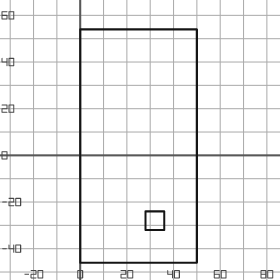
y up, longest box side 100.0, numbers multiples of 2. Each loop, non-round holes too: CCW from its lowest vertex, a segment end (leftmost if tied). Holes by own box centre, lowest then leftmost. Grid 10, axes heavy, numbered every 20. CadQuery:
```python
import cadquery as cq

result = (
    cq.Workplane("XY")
    .moveTo(0.0, -46.0)
    .lineTo(50.0, -46.0)
    .lineTo(50.0, 54.0)
    .lineTo(0.0, 54.0)
    .close()
    .moveTo(28.0, -32.0)
    .lineTo(36.0, -32.0)
    .lineTo(36.0, -24.0)
    .lineTo(28.0, -24.0)
    .close()
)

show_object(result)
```